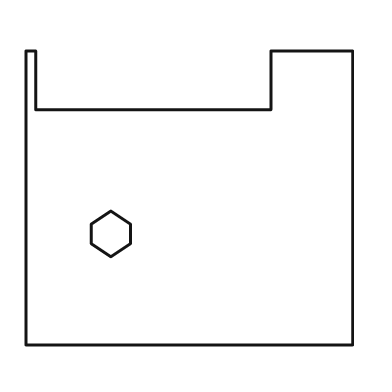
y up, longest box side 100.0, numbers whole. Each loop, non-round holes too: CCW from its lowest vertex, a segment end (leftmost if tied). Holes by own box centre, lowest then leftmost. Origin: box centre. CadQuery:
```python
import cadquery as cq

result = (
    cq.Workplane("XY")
    .moveTo(-50.0, -45.0)
    .lineTo(50.0, -45.0)
    .lineTo(50.0, 45.0)
    .lineTo(25.0, 45.0)
    .lineTo(25.0, 27.0)
    .lineTo(-47.0, 27.0)
    .lineTo(-47.0, 45.0)
    .lineTo(-50.0, 45.0)
    .close()
    .moveTo(-24.0, -18.0)
    .lineTo(-18.0, -14.0)
    .lineTo(-18.0, -8.0)
    .lineTo(-24.0, -4.0)
    .lineTo(-30.0, -8.0)
    .lineTo(-30.0, -14.0)
    .close()
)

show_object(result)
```